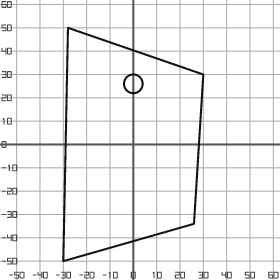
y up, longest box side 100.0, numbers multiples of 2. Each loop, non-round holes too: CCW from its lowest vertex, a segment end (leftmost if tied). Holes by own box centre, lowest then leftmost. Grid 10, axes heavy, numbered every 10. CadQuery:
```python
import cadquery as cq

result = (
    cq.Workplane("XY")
    .moveTo(-30.0, -50.0)
    .lineTo(26.0, -34.0)
    .lineTo(30.0, 30.0)
    .lineTo(-28.0, 50.0)
    .close()
    .moveTo(0.0, 26.0)
    .circle(4.0)
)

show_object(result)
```